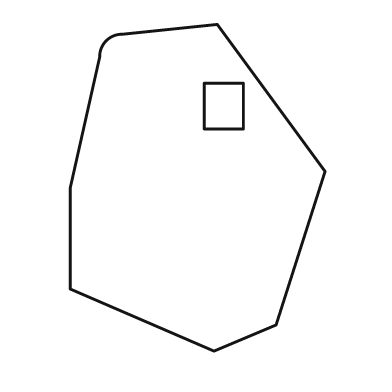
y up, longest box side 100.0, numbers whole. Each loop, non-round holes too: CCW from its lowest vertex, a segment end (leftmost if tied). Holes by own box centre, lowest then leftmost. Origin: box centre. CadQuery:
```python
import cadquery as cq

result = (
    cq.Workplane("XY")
    .moveTo(5.0, -50.0)
    .lineTo(24.0, -42.0)
    .lineTo(39.0, 5.0)
    .lineTo(6.0, 50.0)
    .lineTo(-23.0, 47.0)
    .threePointArc((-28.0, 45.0), (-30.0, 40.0))
    .lineTo(-39.0, 0.0)
    .lineTo(-39.0, -31.0)
    .close()
    .moveTo(2.0, 18.0)
    .lineTo(14.0, 18.0)
    .lineTo(14.0, 32.0)
    .lineTo(2.0, 32.0)
    .close()
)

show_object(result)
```